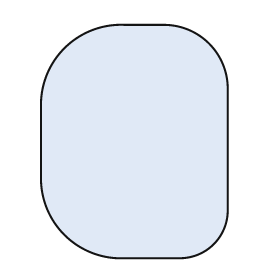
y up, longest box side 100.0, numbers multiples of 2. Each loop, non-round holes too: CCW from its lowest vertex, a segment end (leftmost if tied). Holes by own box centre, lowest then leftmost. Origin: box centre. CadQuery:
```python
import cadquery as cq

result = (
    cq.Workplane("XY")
    .moveTo(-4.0, -50.0)
    .lineTo(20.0, -50.0)
    .threePointArc((34.0, -44.0), (40.0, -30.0))
    .lineTo(40.0, 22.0)
    .threePointArc((32.0, 42.0), (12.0, 50.0))
    .lineTo(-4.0, 50.0)
    .threePointArc((-30.0, 40.0), (-40.0, 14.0))
    .lineTo(-40.0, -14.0)
    .threePointArc((-30.0, -40.0), (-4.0, -50.0))
    .close()
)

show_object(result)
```